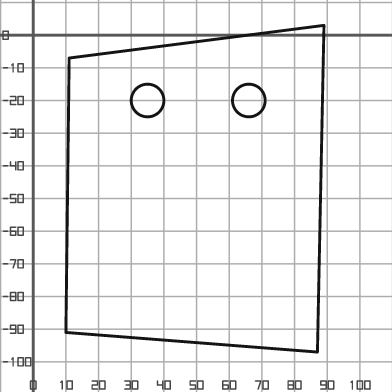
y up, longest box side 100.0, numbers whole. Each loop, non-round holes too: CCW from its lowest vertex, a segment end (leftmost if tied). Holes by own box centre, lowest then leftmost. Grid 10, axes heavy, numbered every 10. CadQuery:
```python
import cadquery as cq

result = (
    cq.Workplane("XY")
    .moveTo(87.0, -97.0)
    .lineTo(89.0, 3.0)
    .lineTo(11.0, -7.0)
    .lineTo(10.0, -91.0)
    .close()
    .moveTo(35.0, -20.0)
    .circle(5.0)
    .moveTo(66.0, -20.0)
    .circle(5.0)
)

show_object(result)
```